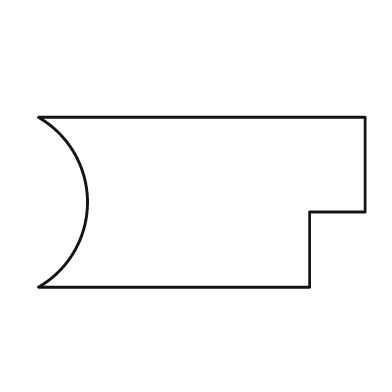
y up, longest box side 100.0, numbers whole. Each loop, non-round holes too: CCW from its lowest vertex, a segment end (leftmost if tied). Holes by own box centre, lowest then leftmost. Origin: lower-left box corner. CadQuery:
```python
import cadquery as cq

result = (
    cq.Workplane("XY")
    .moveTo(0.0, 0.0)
    .lineTo(83.0, 0.0)
    .lineTo(83.0, 23.0)
    .lineTo(100.0, 23.0)
    .lineTo(100.0, 52.0)
    .lineTo(0.0, 52.0)
    .threePointArc((15.0, 26.0), (0.0, 0.0))
    .close()
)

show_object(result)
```